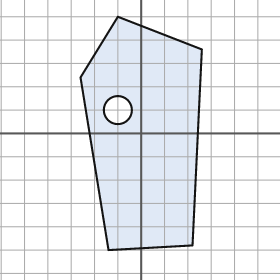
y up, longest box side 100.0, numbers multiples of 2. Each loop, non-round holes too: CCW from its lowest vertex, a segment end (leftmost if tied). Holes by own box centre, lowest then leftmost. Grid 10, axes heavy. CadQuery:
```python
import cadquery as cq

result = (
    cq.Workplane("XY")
    .moveTo(-14.0, -50.0)
    .lineTo(22.0, -48.0)
    .lineTo(26.0, 36.0)
    .lineTo(-10.0, 50.0)
    .lineTo(-26.0, 24.0)
    .close()
    .moveTo(-10.0, 10.0)
    .circle(6.0)
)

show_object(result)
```